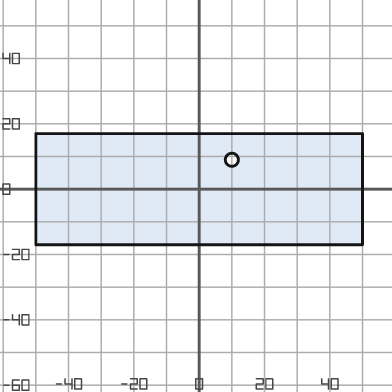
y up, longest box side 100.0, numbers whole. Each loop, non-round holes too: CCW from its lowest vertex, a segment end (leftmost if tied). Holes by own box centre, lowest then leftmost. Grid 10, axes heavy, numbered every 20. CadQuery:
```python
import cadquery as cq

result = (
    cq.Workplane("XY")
    .moveTo(-50.0, -17.0)
    .lineTo(50.0, -17.0)
    .lineTo(50.0, 17.0)
    .lineTo(-50.0, 17.0)
    .close()
    .moveTo(10.0, 9.0)
    .circle(2.0)
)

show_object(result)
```